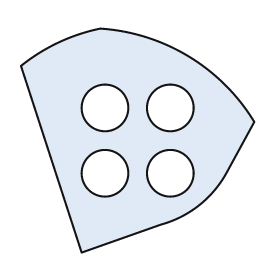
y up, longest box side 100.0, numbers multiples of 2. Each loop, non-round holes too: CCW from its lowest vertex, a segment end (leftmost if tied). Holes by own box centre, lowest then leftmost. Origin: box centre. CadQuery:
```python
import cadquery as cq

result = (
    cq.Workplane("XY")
    .moveTo(-24.0, -48.0)
    .lineTo(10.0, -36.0)
    .threePointArc((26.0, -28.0), (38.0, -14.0))
    .lineTo(50.0, 8.0)
    .threePointArc((22.0, 36.0), (-16.0, 48.0))
    .threePointArc((-34.0, 42.0), (-50.0, 32.0))
    .close()
    .moveTo(-14.0, -14.0)
    .circle(10.0)
    .moveTo(14.0, -14.0)
    .circle(10.0)
    .moveTo(-14.0, 14.0)
    .circle(10.0)
    .moveTo(14.0, 14.0)
    .circle(10.0)
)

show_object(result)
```